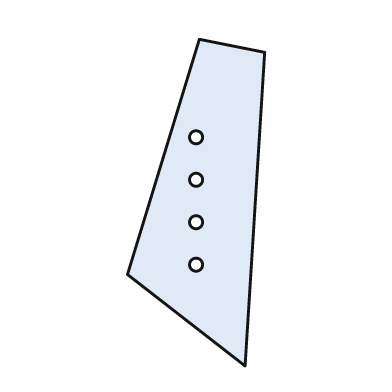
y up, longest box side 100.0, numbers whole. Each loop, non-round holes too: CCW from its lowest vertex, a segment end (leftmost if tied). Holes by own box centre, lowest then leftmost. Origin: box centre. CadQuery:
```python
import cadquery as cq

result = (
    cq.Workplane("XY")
    .moveTo(15.0, -50.0)
    .lineTo(21.0, 46.0)
    .lineTo(1.0, 50.0)
    .lineTo(-21.0, -22.0)
    .close()
    .moveTo(0.0, -19.0)
    .circle(2.0)
    .moveTo(0.0, -6.0)
    .circle(2.0)
    .moveTo(0.0, 7.0)
    .circle(2.0)
    .moveTo(0.0, 20.0)
    .circle(2.0)
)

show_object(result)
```